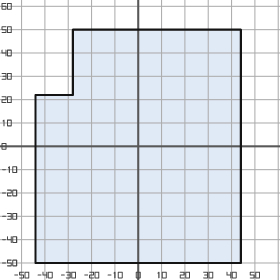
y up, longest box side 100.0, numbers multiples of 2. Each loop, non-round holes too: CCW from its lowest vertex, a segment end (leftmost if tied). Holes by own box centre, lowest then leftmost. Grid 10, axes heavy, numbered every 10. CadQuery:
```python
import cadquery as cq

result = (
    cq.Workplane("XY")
    .moveTo(-44.0, -50.0)
    .lineTo(44.0, -50.0)
    .lineTo(44.0, 50.0)
    .lineTo(-28.0, 50.0)
    .lineTo(-28.0, 22.0)
    .lineTo(-44.0, 22.0)
    .close()
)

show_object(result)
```